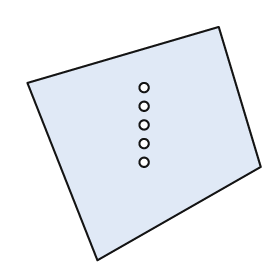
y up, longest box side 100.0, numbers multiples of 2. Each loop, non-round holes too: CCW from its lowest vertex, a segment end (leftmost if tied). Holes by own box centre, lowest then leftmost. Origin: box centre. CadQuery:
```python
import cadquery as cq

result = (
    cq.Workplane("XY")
    .moveTo(-20.0, -50.0)
    .lineTo(50.0, -10.0)
    .lineTo(32.0, 50.0)
    .lineTo(-50.0, 26.0)
    .close()
    .moveTo(0.0, -8.0)
    .circle(2.0)
    .moveTo(0.0, 0.0)
    .circle(2.0)
    .moveTo(0.0, 8.0)
    .circle(2.0)
    .moveTo(0.0, 16.0)
    .circle(2.0)
    .moveTo(0.0, 24.0)
    .circle(2.0)
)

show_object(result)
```